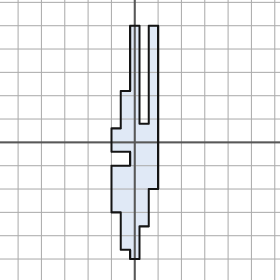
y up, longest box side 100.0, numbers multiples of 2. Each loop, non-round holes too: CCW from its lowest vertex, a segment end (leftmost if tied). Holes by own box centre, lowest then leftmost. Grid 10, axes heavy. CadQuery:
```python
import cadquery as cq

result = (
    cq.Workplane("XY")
    .moveTo(-2.0, -50.0)
    .lineTo(2.0, -50.0)
    .lineTo(2.0, -36.0)
    .lineTo(6.0, -36.0)
    .lineTo(6.0, -20.0)
    .lineTo(10.0, -20.0)
    .lineTo(10.0, 50.0)
    .lineTo(6.0, 50.0)
    .lineTo(6.0, 8.0)
    .lineTo(2.0, 8.0)
    .lineTo(2.0, 50.0)
    .lineTo(-2.0, 50.0)
    .lineTo(-2.0, 22.0)
    .lineTo(-6.0, 22.0)
    .lineTo(-6.0, 6.0)
    .lineTo(-10.0, 6.0)
    .lineTo(-10.0, -4.0)
    .lineTo(-2.0, -4.0)
    .lineTo(-2.0, -10.0)
    .lineTo(-10.0, -10.0)
    .lineTo(-10.0, -30.0)
    .lineTo(-6.0, -30.0)
    .lineTo(-6.0, -46.0)
    .lineTo(-2.0, -46.0)
    .close()
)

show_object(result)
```